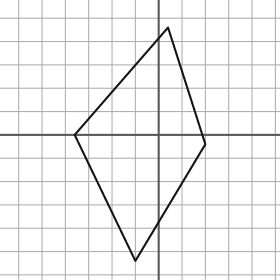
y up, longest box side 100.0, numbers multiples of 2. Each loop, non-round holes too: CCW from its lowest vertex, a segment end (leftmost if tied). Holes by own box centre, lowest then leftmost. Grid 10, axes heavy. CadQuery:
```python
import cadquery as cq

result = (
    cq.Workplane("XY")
    .moveTo(-10.0, -54.0)
    .lineTo(20.0, -4.0)
    .lineTo(4.0, 46.0)
    .lineTo(-36.0, 0.0)
    .close()
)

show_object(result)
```